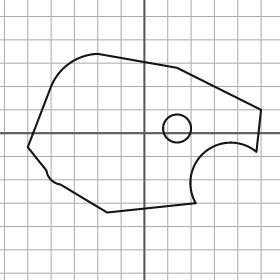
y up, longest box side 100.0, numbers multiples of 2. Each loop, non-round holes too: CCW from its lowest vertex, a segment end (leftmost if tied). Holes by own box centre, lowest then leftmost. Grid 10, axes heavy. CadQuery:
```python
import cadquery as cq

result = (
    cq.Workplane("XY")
    .moveTo(-16.0, -34.0)
    .lineTo(22.0, -30.0)
    .threePointArc((26.0, -8.0), (48.0, -8.0))
    .lineTo(50.0, 10.0)
    .lineTo(14.0, 28.0)
    .lineTo(-20.0, 34.0)
    .threePointArc((-32.0, 30.0), (-40.0, 20.0))
    .lineTo(-50.0, -6.0)
    .lineTo(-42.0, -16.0)
    .threePointArc((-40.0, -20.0), (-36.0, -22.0))
    .close()
    .moveTo(14.0, 2.0)
    .circle(6.0)
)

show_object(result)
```